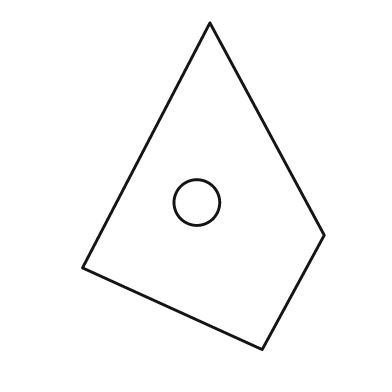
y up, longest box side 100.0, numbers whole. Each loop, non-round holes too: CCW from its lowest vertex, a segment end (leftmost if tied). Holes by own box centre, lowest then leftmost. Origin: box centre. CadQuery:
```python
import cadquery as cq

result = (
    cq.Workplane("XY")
    .moveTo(18.0, -50.0)
    .lineTo(37.0, -15.0)
    .lineTo(2.0, 50.0)
    .lineTo(-37.0, -25.0)
    .close()
    .moveTo(-2.0, -5.0)
    .circle(7.0)
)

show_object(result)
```